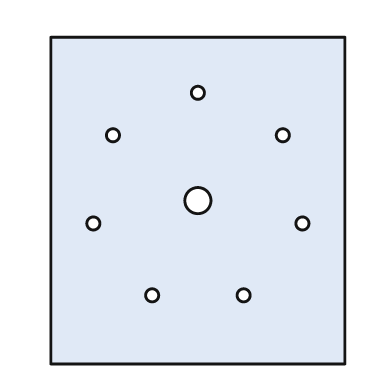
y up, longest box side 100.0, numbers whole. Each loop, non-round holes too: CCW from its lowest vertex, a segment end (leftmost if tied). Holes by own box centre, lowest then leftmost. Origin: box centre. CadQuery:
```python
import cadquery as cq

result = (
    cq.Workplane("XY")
    .moveTo(-45.0, -50.0)
    .lineTo(45.0, -50.0)
    .lineTo(45.0, 50.0)
    .lineTo(-45.0, 50.0)
    .close()
    .moveTo(-14.0, -29.0)
    .circle(2.0)
    .moveTo(14.0, -29.0)
    .circle(2.0)
    .moveTo(-32.0, -7.0)
    .circle(2.0)
    .moveTo(32.0, -7.0)
    .circle(2.0)
    .moveTo(0.0, 0.0)
    .circle(4.0)
    .moveTo(-26.0, 20.0)
    .circle(2.0)
    .moveTo(26.0, 20.0)
    .circle(2.0)
    .moveTo(0.0, 33.0)
    .circle(2.0)
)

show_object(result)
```